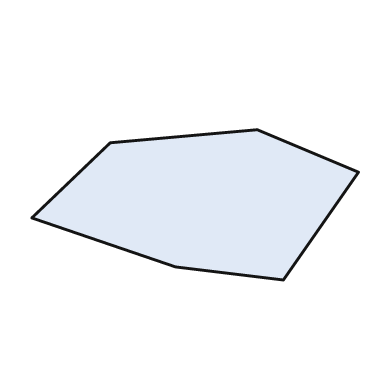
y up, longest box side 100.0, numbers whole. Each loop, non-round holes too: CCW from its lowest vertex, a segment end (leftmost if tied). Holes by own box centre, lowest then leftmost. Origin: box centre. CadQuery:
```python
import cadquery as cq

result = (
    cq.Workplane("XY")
    .moveTo(27.0, -23.0)
    .lineTo(50.0, 10.0)
    .lineTo(19.0, 23.0)
    .lineTo(-26.0, 19.0)
    .lineTo(-50.0, -4.0)
    .lineTo(-6.0, -19.0)
    .close()
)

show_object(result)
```